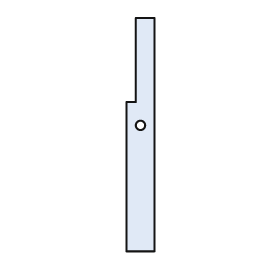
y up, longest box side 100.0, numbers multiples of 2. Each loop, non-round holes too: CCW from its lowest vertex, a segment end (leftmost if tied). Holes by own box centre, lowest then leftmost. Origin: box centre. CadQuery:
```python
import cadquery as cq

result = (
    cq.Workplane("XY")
    .moveTo(-6.0, -50.0)
    .lineTo(6.0, -50.0)
    .lineTo(6.0, 50.0)
    .lineTo(-2.0, 50.0)
    .lineTo(-2.0, 14.0)
    .lineTo(-6.0, 14.0)
    .close()
    .moveTo(0.0, 4.0)
    .circle(2.0)
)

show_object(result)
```